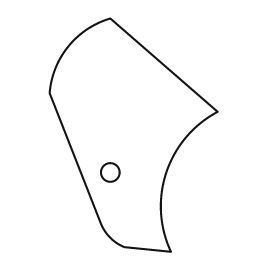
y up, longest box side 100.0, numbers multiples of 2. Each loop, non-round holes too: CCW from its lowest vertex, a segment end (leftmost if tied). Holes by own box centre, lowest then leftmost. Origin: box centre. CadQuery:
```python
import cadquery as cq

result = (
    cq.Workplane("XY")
    .moveTo(16.0, -50.0)
    .threePointArc((14.0, -16.0), (36.0, 10.0))
    .lineTo(-10.0, 50.0)
    .threePointArc((-28.0, 38.0), (-36.0, 18.0))
    .lineTo(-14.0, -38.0)
    .threePointArc((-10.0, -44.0), (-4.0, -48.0))
    .close()
    .moveTo(-10.0, -16.0)
    .circle(4.0)
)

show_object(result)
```